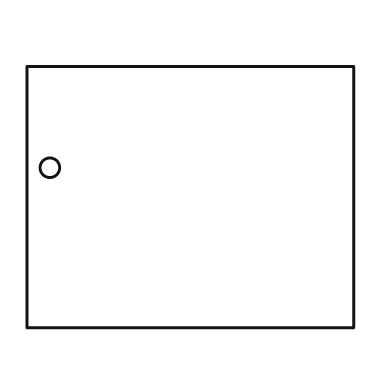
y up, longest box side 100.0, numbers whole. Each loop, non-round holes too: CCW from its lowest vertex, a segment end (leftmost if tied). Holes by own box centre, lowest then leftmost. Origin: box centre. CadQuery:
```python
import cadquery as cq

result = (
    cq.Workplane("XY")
    .moveTo(-50.0, -40.0)
    .lineTo(50.0, -40.0)
    .lineTo(50.0, 40.0)
    .lineTo(-50.0, 40.0)
    .close()
    .moveTo(-43.0, 9.0)
    .circle(3.0)
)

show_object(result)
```